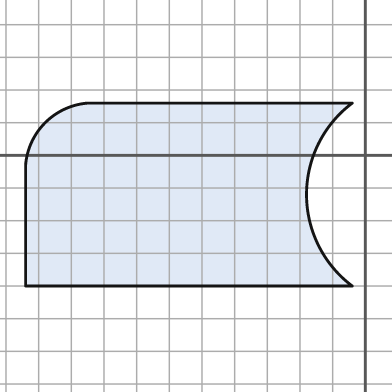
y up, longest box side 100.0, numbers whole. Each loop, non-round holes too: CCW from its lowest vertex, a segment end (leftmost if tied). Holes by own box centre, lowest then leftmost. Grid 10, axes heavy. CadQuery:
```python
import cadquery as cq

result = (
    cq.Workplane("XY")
    .moveTo(-104.0, -40.0)
    .lineTo(-4.0, -40.0)
    .threePointArc((-18.0, -12.0), (-4.0, 16.0))
    .lineTo(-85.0, 16.0)
    .threePointArc((-98.0, 10.0), (-104.0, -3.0))
    .close()
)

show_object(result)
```